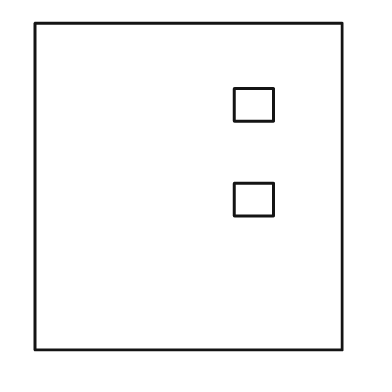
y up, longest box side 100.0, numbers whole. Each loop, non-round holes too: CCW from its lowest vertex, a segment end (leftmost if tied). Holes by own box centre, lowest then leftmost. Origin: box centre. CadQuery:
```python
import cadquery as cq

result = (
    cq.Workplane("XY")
    .moveTo(-47.0, -50.0)
    .lineTo(47.0, -50.0)
    .lineTo(47.0, 50.0)
    .lineTo(-47.0, 50.0)
    .close()
    .moveTo(14.0, -9.0)
    .lineTo(26.0, -9.0)
    .lineTo(26.0, 1.0)
    .lineTo(14.0, 1.0)
    .close()
    .moveTo(14.0, 20.0)
    .lineTo(26.0, 20.0)
    .lineTo(26.0, 30.0)
    .lineTo(14.0, 30.0)
    .close()
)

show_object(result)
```